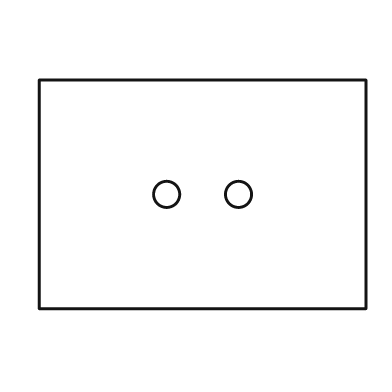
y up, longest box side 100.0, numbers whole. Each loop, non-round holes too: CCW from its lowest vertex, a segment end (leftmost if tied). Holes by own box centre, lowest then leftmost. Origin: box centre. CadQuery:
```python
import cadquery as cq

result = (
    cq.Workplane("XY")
    .moveTo(-50.0, -35.0)
    .lineTo(50.0, -35.0)
    .lineTo(50.0, 35.0)
    .lineTo(-50.0, 35.0)
    .close()
    .moveTo(-11.0, 0.0)
    .circle(4.0)
    .moveTo(11.0, 0.0)
    .circle(4.0)
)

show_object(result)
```